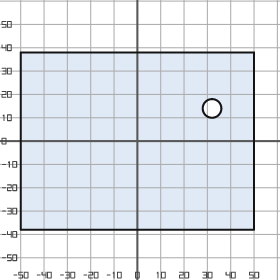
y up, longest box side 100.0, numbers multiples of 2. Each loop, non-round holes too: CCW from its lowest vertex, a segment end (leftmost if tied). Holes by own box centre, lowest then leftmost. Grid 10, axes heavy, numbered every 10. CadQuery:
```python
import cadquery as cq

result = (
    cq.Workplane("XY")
    .moveTo(-50.0, -38.0)
    .lineTo(50.0, -38.0)
    .lineTo(50.0, 38.0)
    .lineTo(-50.0, 38.0)
    .close()
    .moveTo(32.0, 14.0)
    .circle(4.0)
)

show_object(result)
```